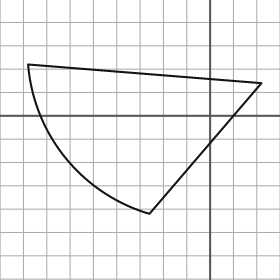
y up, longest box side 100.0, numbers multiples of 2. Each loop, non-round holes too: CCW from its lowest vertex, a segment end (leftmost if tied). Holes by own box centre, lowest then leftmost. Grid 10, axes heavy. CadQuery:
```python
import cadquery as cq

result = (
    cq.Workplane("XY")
    .moveTo(-26.0, -42.0)
    .lineTo(22.0, 14.0)
    .lineTo(-78.0, 22.0)
    .threePointArc((-62.0, -18.0), (-26.0, -42.0))
    .close()
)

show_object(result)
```